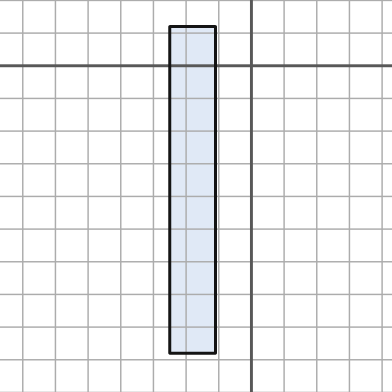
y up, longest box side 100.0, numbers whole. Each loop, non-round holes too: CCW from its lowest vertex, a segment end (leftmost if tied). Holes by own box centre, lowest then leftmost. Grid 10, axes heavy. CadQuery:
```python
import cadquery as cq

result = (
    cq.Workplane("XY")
    .moveTo(-25.0, -88.0)
    .lineTo(-11.0, -88.0)
    .lineTo(-11.0, 12.0)
    .lineTo(-25.0, 12.0)
    .close()
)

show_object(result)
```